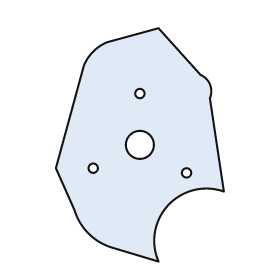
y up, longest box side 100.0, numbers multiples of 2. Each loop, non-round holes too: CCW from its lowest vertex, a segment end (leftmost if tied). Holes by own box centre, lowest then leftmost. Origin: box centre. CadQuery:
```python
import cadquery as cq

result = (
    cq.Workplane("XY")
    .moveTo(8.0, -50.0)
    .threePointArc((12.0, -26.0), (36.0, -20.0))
    .lineTo(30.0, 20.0)
    .threePointArc((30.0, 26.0), (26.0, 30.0))
    .lineTo(8.0, 50.0)
    .lineTo(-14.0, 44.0)
    .threePointArc((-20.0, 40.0), (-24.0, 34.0))
    .lineTo(-36.0, -10.0)
    .lineTo(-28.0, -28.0)
    .threePointArc((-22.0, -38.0), (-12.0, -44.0))
    .close()
    .moveTo(20.0, -12.0)
    .circle(2.0)
    .moveTo(-20.0, -10.0)
    .circle(2.0)
    .moveTo(0.0, 0.0)
    .circle(6.0)
    .moveTo(0.0, 22.0)
    .circle(2.0)
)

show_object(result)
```